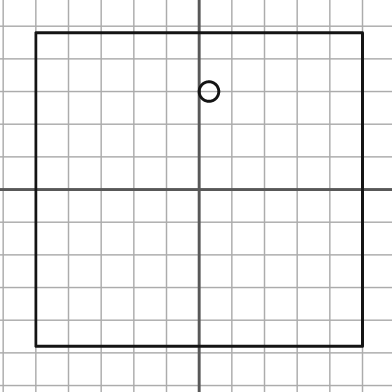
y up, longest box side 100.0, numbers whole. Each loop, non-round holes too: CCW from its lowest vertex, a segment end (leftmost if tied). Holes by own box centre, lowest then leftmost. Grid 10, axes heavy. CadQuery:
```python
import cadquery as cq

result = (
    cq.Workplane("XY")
    .moveTo(-50.0, -48.0)
    .lineTo(50.0, -48.0)
    .lineTo(50.0, 48.0)
    .lineTo(-50.0, 48.0)
    .close()
    .moveTo(3.0, 30.0)
    .circle(3.0)
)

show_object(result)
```